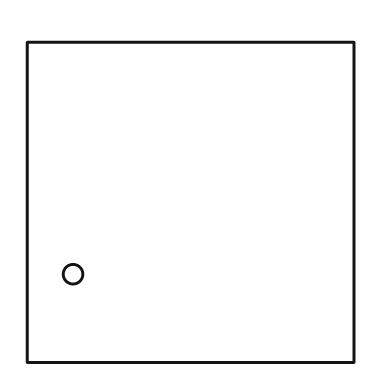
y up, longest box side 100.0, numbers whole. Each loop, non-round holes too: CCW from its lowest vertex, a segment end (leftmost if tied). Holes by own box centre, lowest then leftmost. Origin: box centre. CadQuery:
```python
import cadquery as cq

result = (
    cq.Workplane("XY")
    .moveTo(-50.0, -49.0)
    .lineTo(50.0, -49.0)
    .lineTo(50.0, 49.0)
    .lineTo(-50.0, 49.0)
    .close()
    .moveTo(-36.0, -22.0)
    .circle(3.0)
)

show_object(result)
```